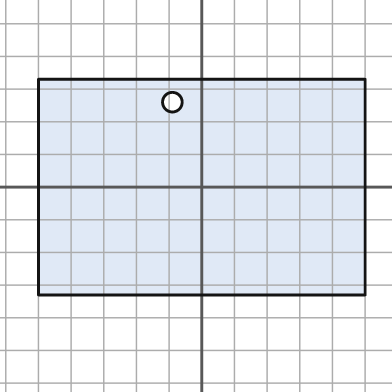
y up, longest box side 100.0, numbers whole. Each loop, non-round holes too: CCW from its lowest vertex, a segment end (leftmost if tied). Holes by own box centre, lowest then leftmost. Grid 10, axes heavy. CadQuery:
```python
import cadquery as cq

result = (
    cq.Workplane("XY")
    .moveTo(-50.0, -33.0)
    .lineTo(50.0, -33.0)
    .lineTo(50.0, 33.0)
    .lineTo(-50.0, 33.0)
    .close()
    .moveTo(-9.0, 26.0)
    .circle(3.0)
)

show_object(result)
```